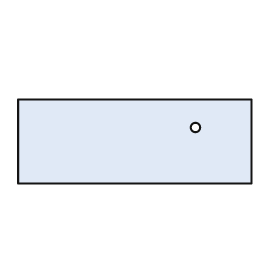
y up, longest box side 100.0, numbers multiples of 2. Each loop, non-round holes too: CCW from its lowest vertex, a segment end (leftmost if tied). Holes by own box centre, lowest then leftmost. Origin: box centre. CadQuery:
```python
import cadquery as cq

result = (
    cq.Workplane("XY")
    .moveTo(-50.0, -18.0)
    .lineTo(50.0, -18.0)
    .lineTo(50.0, 18.0)
    .lineTo(-50.0, 18.0)
    .close()
    .moveTo(26.0, 6.0)
    .circle(2.0)
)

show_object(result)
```